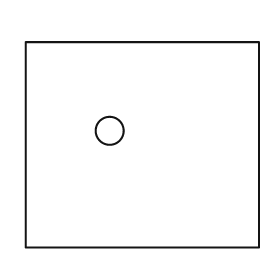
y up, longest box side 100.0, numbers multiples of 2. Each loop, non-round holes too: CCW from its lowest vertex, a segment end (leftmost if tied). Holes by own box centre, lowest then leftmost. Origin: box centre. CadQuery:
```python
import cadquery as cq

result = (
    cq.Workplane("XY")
    .moveTo(-50.0, -44.0)
    .lineTo(50.0, -44.0)
    .lineTo(50.0, 44.0)
    .lineTo(-50.0, 44.0)
    .close()
    .moveTo(-14.0, 6.0)
    .circle(6.0)
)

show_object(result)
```